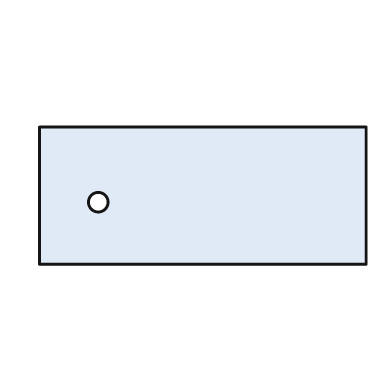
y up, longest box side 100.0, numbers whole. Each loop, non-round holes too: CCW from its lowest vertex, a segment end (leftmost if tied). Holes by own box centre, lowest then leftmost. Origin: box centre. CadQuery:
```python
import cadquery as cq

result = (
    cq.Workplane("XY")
    .moveTo(-50.0, -21.0)
    .lineTo(50.0, -21.0)
    .lineTo(50.0, 21.0)
    .lineTo(-50.0, 21.0)
    .close()
    .moveTo(-32.0, -2.0)
    .circle(3.0)
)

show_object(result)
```